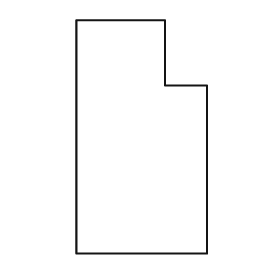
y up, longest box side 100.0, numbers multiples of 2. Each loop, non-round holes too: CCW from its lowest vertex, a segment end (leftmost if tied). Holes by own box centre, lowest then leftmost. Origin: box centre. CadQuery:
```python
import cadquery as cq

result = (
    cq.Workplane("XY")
    .moveTo(-28.0, -50.0)
    .lineTo(28.0, -50.0)
    .lineTo(28.0, 22.0)
    .lineTo(10.0, 22.0)
    .lineTo(10.0, 50.0)
    .lineTo(-28.0, 50.0)
    .close()
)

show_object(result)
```